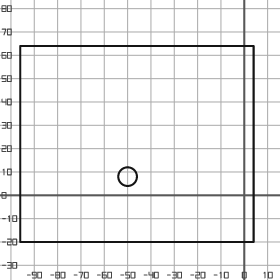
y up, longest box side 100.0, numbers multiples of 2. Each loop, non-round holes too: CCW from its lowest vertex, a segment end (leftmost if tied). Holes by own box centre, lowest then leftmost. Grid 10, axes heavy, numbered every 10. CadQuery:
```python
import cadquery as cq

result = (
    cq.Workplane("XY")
    .moveTo(-96.0, -20.0)
    .lineTo(4.0, -20.0)
    .lineTo(4.0, 64.0)
    .lineTo(-96.0, 64.0)
    .close()
    .moveTo(-50.0, 8.0)
    .circle(4.0)
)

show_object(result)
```